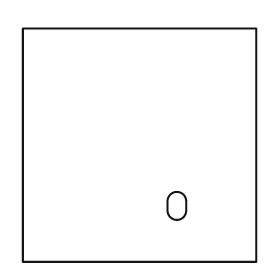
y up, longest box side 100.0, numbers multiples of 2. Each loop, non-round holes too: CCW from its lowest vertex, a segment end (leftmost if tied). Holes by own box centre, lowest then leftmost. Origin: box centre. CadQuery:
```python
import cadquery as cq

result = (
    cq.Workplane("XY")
    .moveTo(-50.0, -50.0)
    .lineTo(50.0, -50.0)
    .lineTo(50.0, 50.0)
    .lineTo(-50.0, 50.0)
    .close()
    .moveTo(12.0, -28.0)
    .threePointArc((16.0, -32.0), (20.0, -28.0))
    .lineTo(20.0, -24.0)
    .threePointArc((16.0, -20.0), (12.0, -24.0))
    .close()
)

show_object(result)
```